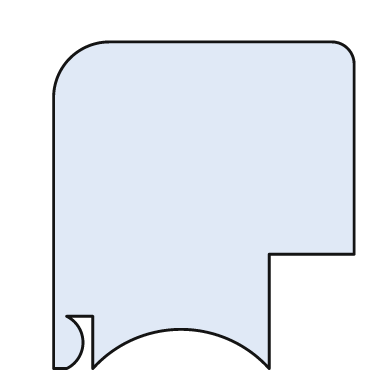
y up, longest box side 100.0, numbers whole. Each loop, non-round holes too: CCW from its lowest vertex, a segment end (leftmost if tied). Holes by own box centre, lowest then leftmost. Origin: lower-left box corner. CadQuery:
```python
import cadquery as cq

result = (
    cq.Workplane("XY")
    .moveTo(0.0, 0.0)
    .lineTo(4.0, 0.0)
    .threePointArc((9.0, 8.0), (4.0, 16.0))
    .lineTo(12.0, 16.0)
    .lineTo(12.0, 0.0)
    .threePointArc((39.0, 12.0), (66.0, 0.0))
    .lineTo(66.0, 35.0)
    .lineTo(92.0, 35.0)
    .lineTo(92.0, 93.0)
    .threePointArc((90.0, 98.0), (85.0, 100.0))
    .lineTo(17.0, 100.0)
    .threePointArc((5.0, 95.0), (0.0, 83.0))
    .close()
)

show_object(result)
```